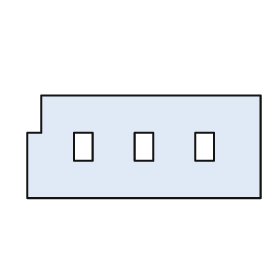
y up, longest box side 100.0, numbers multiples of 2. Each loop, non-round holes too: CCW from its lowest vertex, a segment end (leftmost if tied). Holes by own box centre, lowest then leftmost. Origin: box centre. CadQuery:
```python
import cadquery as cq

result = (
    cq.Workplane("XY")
    .moveTo(-50.0, -22.0)
    .lineTo(50.0, -22.0)
    .lineTo(50.0, 22.0)
    .lineTo(-44.0, 22.0)
    .lineTo(-44.0, 6.0)
    .lineTo(-50.0, 6.0)
    .close()
    .moveTo(-30.0, -6.0)
    .lineTo(-22.0, -6.0)
    .lineTo(-22.0, 6.0)
    .lineTo(-30.0, 6.0)
    .close()
    .moveTo(-4.0, -6.0)
    .lineTo(4.0, -6.0)
    .lineTo(4.0, 6.0)
    .lineTo(-4.0, 6.0)
    .close()
    .moveTo(22.0, -6.0)
    .lineTo(30.0, -6.0)
    .lineTo(30.0, 6.0)
    .lineTo(22.0, 6.0)
    .close()
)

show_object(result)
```